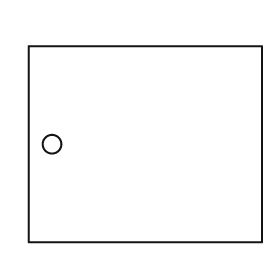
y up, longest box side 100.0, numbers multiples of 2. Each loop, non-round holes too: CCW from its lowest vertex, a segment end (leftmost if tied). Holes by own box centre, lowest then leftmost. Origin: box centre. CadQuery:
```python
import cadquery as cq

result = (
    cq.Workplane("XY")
    .moveTo(-50.0, -42.0)
    .lineTo(50.0, -42.0)
    .lineTo(50.0, 42.0)
    .lineTo(-50.0, 42.0)
    .close()
    .moveTo(-40.0, 0.0)
    .circle(4.0)
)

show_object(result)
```